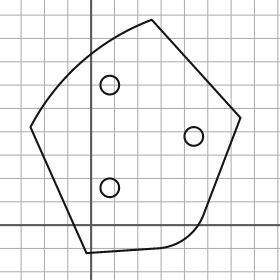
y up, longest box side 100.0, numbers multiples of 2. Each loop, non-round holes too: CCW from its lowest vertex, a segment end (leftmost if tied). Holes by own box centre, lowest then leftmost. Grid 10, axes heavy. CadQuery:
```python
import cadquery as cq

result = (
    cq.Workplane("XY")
    .moveTo(-2.0, -12.0)
    .lineTo(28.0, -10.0)
    .threePointArc((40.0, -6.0), (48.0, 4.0))
    .lineTo(64.0, 46.0)
    .lineTo(26.0, 88.0)
    .threePointArc((-4.0, 70.0), (-26.0, 42.0))
    .close()
    .moveTo(8.0, 16.0)
    .circle(4.0)
    .moveTo(44.0, 38.0)
    .circle(4.0)
    .moveTo(8.0, 60.0)
    .circle(4.0)
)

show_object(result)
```